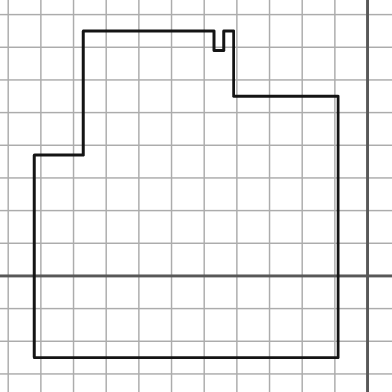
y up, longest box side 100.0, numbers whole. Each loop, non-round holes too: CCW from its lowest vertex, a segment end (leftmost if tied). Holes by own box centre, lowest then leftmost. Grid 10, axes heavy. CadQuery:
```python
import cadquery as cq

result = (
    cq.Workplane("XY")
    .moveTo(-102.0, -25.0)
    .lineTo(-9.0, -25.0)
    .lineTo(-9.0, 55.0)
    .lineTo(-41.0, 55.0)
    .lineTo(-41.0, 75.0)
    .lineTo(-44.0, 75.0)
    .lineTo(-44.0, 69.0)
    .lineTo(-47.0, 69.0)
    .lineTo(-47.0, 75.0)
    .lineTo(-87.0, 75.0)
    .lineTo(-87.0, 37.0)
    .lineTo(-102.0, 37.0)
    .close()
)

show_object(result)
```